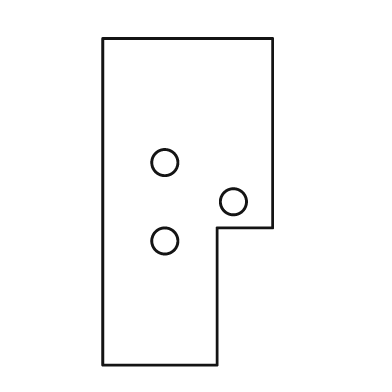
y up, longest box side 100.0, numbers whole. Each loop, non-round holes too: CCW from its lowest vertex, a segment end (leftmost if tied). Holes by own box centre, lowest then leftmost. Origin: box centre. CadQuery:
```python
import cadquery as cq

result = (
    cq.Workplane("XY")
    .moveTo(-26.0, -50.0)
    .lineTo(9.0, -50.0)
    .lineTo(9.0, -8.0)
    .lineTo(26.0, -8.0)
    .lineTo(26.0, 50.0)
    .lineTo(-26.0, 50.0)
    .close()
    .moveTo(-7.0, -12.0)
    .circle(4.0)
    .moveTo(14.0, 0.0)
    .circle(4.0)
    .moveTo(-7.0, 12.0)
    .circle(4.0)
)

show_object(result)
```